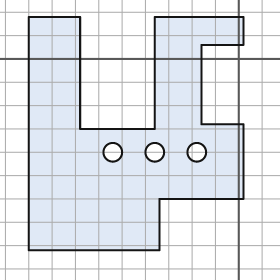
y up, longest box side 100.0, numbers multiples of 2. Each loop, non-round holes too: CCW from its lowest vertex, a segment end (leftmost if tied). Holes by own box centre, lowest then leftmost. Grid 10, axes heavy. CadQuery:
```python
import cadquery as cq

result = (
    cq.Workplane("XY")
    .moveTo(-90.0, -82.0)
    .lineTo(-34.0, -82.0)
    .lineTo(-34.0, -60.0)
    .lineTo(2.0, -60.0)
    .lineTo(2.0, -28.0)
    .lineTo(-16.0, -28.0)
    .lineTo(-16.0, 6.0)
    .lineTo(2.0, 6.0)
    .lineTo(2.0, 18.0)
    .lineTo(-36.0, 18.0)
    .lineTo(-36.0, -30.0)
    .lineTo(-68.0, -30.0)
    .lineTo(-68.0, 18.0)
    .lineTo(-90.0, 18.0)
    .close()
    .moveTo(-54.0, -40.0)
    .circle(4.0)
    .moveTo(-36.0, -40.0)
    .circle(4.0)
    .moveTo(-18.0, -40.0)
    .circle(4.0)
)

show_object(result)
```